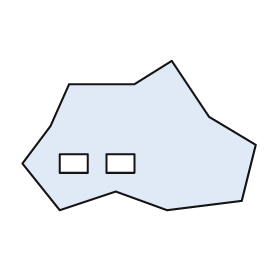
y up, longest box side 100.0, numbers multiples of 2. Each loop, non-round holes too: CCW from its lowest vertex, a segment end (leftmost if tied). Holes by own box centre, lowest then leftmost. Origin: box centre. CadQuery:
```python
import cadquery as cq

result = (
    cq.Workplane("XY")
    .moveTo(-34.0, -32.0)
    .lineTo(-10.0, -24.0)
    .lineTo(12.0, -32.0)
    .lineTo(44.0, -28.0)
    .lineTo(50.0, -4.0)
    .lineTo(30.0, 8.0)
    .lineTo(14.0, 32.0)
    .lineTo(-2.0, 22.0)
    .lineTo(-30.0, 22.0)
    .lineTo(-38.0, 4.0)
    .lineTo(-50.0, -12.0)
    .close()
    .moveTo(-34.0, -16.0)
    .lineTo(-22.0, -16.0)
    .lineTo(-22.0, -8.0)
    .lineTo(-34.0, -8.0)
    .close()
    .moveTo(-14.0, -16.0)
    .lineTo(-2.0, -16.0)
    .lineTo(-2.0, -8.0)
    .lineTo(-14.0, -8.0)
    .close()
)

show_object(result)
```